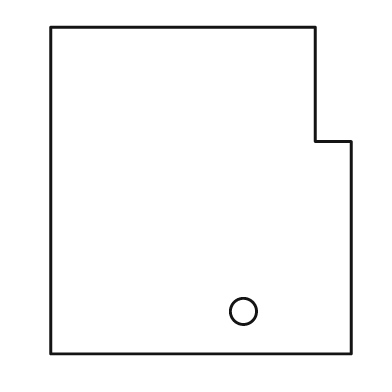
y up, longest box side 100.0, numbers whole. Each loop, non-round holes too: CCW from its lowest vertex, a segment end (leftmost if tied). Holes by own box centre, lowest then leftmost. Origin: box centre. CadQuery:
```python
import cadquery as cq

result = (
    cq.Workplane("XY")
    .moveTo(-46.0, -50.0)
    .lineTo(46.0, -50.0)
    .lineTo(46.0, 15.0)
    .lineTo(35.0, 15.0)
    .lineTo(35.0, 50.0)
    .lineTo(-46.0, 50.0)
    .close()
    .moveTo(13.0, -37.0)
    .circle(4.0)
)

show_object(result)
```